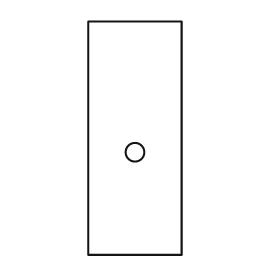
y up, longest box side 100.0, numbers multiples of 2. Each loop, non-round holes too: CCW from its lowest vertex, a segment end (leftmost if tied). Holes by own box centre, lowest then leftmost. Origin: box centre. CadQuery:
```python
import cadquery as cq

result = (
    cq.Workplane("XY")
    .moveTo(-20.0, -50.0)
    .lineTo(20.0, -50.0)
    .lineTo(20.0, 50.0)
    .lineTo(-20.0, 50.0)
    .close()
    .moveTo(0.0, -6.0)
    .circle(4.0)
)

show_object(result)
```